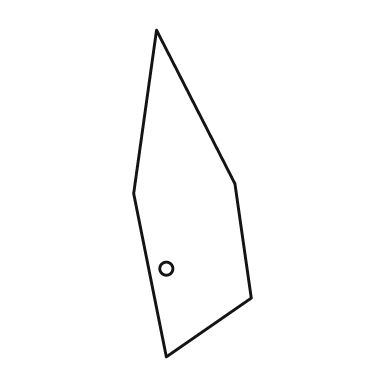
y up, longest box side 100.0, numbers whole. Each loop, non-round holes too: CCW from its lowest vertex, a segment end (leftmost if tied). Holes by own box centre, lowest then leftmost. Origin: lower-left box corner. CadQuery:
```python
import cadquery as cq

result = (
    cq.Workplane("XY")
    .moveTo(10.0, 0.0)
    .lineTo(36.0, 18.0)
    .lineTo(31.0, 53.0)
    .lineTo(7.0, 100.0)
    .lineTo(0.0, 50.0)
    .close()
    .moveTo(10.0, 27.0)
    .circle(2.0)
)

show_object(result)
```